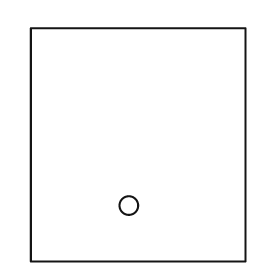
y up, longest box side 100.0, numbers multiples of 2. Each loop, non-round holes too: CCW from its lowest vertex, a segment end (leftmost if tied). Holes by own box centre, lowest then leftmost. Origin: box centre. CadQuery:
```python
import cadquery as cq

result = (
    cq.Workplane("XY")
    .moveTo(-46.0, -50.0)
    .lineTo(46.0, -50.0)
    .lineTo(46.0, 50.0)
    .lineTo(-46.0, 50.0)
    .close()
    .moveTo(-4.0, -26.0)
    .circle(4.0)
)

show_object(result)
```